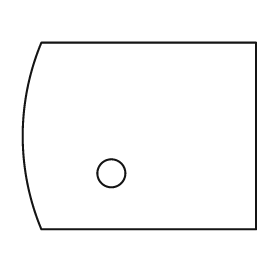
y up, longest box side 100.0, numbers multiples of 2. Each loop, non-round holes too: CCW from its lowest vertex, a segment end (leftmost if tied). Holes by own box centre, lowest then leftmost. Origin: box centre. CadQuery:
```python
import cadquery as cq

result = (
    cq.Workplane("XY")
    .moveTo(-42.0, -40.0)
    .lineTo(50.0, -40.0)
    .lineTo(50.0, 40.0)
    .lineTo(-42.0, 40.0)
    .threePointArc((-50.0, 0.0), (-42.0, -40.0))
    .close()
    .moveTo(-12.0, -16.0)
    .circle(6.0)
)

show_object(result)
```